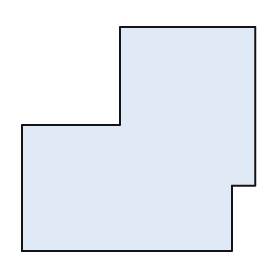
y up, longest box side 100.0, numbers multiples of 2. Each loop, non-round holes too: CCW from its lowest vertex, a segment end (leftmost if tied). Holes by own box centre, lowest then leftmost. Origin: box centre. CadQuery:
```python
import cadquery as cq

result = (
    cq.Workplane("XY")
    .moveTo(-50.0, -48.0)
    .lineTo(40.0, -48.0)
    .lineTo(40.0, -20.0)
    .lineTo(50.0, -20.0)
    .lineTo(50.0, 48.0)
    .lineTo(-8.0, 48.0)
    .lineTo(-8.0, 6.0)
    .lineTo(-50.0, 6.0)
    .close()
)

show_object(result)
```